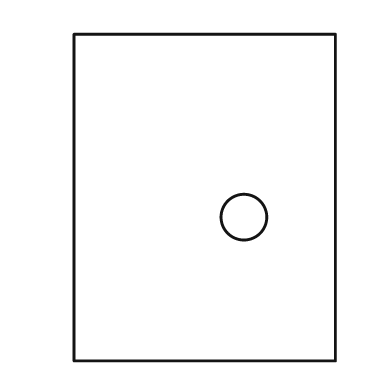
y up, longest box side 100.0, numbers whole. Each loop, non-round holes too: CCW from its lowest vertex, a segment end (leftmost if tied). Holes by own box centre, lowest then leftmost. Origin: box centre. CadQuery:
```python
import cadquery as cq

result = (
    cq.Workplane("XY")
    .moveTo(-40.0, -50.0)
    .lineTo(40.0, -50.0)
    .lineTo(40.0, 50.0)
    .lineTo(-40.0, 50.0)
    .close()
    .moveTo(12.0, -6.0)
    .circle(7.0)
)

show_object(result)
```